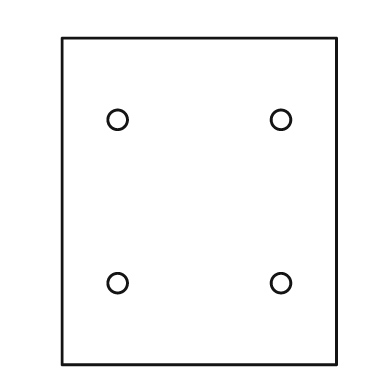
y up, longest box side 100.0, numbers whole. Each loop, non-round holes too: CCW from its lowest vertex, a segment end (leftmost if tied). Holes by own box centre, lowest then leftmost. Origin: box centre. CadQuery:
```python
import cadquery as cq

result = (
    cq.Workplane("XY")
    .moveTo(-42.0, -50.0)
    .lineTo(42.0, -50.0)
    .lineTo(42.0, 50.0)
    .lineTo(-42.0, 50.0)
    .close()
    .moveTo(-25.0, -25.0)
    .circle(3.0)
    .moveTo(25.0, -25.0)
    .circle(3.0)
    .moveTo(-25.0, 25.0)
    .circle(3.0)
    .moveTo(25.0, 25.0)
    .circle(3.0)
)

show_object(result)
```